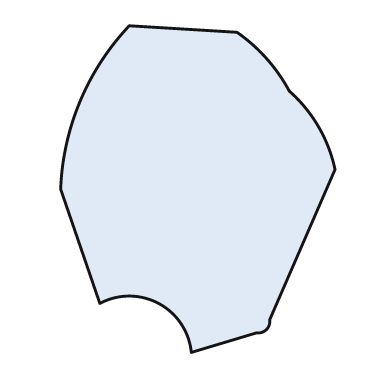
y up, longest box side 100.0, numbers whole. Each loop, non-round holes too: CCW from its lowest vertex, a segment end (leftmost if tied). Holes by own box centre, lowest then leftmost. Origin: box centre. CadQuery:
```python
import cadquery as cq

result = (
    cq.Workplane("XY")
    .moveTo(-2.0, -50.0)
    .lineTo(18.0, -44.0)
    .threePointArc((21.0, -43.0), (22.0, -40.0))
    .lineTo(42.0, 6.0)
    .threePointArc((37.0, 19.0), (28.0, 30.0))
    .threePointArc((21.0, 40.0), (12.0, 48.0))
    .lineTo(-21.0, 50.0)
    .threePointArc((-36.0, 27.0), (-42.0, 0.0))
    .lineTo(-30.0, -35.0)
    .threePointArc((-12.0, -35.0), (-2.0, -50.0))
    .close()
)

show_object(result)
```